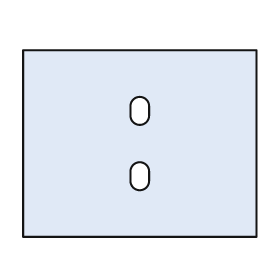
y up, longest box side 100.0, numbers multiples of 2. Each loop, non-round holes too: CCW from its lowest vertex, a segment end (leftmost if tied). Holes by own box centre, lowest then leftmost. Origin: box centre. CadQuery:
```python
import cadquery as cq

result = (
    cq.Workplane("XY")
    .moveTo(-50.0, -40.0)
    .lineTo(50.0, -40.0)
    .lineTo(50.0, 40.0)
    .lineTo(-50.0, 40.0)
    .close()
    .moveTo(-4.0, -16.0)
    .threePointArc((0.0, -20.0), (4.0, -16.0))
    .lineTo(4.0, -12.0)
    .threePointArc((0.0, -8.0), (-4.0, -12.0))
    .close()
    .moveTo(-4.0, 12.0)
    .threePointArc((0.0, 8.0), (4.0, 12.0))
    .lineTo(4.0, 16.0)
    .threePointArc((0.0, 20.0), (-4.0, 16.0))
    .close()
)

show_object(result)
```